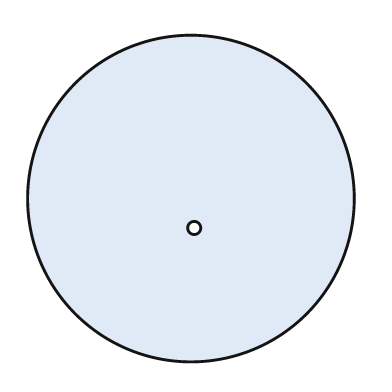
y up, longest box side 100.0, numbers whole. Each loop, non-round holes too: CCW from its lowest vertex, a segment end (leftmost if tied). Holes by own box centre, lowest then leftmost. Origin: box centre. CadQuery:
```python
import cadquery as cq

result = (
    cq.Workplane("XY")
    .moveTo(0.0, 0.0)
    .circle(50.0)
    .moveTo(1.0, -9.0)
    .circle(2.0)
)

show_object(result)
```